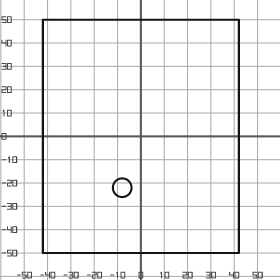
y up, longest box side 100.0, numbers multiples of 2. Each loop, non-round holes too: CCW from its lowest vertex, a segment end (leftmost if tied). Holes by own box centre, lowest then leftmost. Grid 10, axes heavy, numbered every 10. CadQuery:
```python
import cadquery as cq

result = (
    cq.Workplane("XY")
    .moveTo(-42.0, -50.0)
    .lineTo(42.0, -50.0)
    .lineTo(42.0, 50.0)
    .lineTo(-42.0, 50.0)
    .close()
    .moveTo(-8.0, -22.0)
    .circle(4.0)
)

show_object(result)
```